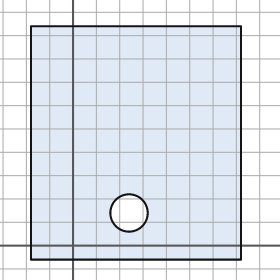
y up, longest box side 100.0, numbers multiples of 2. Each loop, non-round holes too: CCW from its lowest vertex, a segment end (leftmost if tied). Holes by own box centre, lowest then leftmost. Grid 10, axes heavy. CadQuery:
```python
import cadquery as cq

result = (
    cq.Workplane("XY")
    .moveTo(-18.0, -6.0)
    .lineTo(72.0, -6.0)
    .lineTo(72.0, 94.0)
    .lineTo(-18.0, 94.0)
    .close()
    .moveTo(24.0, 14.0)
    .circle(8.0)
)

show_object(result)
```